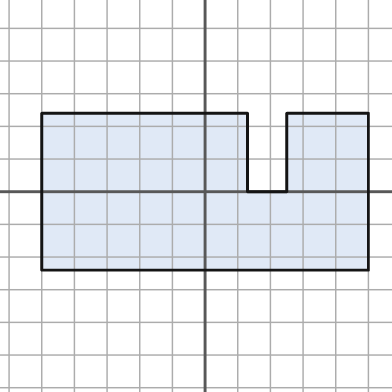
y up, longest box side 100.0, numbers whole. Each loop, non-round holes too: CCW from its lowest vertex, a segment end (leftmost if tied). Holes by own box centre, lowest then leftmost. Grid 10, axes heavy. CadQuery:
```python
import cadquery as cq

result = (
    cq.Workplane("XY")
    .moveTo(-50.0, -24.0)
    .lineTo(50.0, -24.0)
    .lineTo(50.0, 24.0)
    .lineTo(25.0, 24.0)
    .lineTo(25.0, 0.0)
    .lineTo(13.0, 0.0)
    .lineTo(13.0, 24.0)
    .lineTo(-50.0, 24.0)
    .close()
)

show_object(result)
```